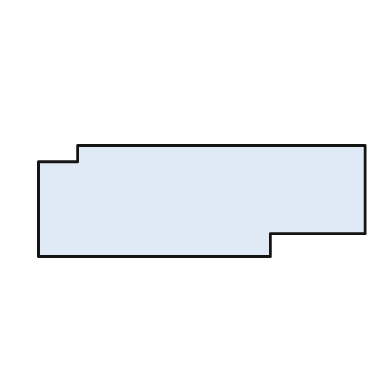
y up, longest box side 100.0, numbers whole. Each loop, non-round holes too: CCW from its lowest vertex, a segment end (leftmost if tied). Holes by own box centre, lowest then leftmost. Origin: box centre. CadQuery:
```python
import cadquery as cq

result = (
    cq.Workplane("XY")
    .moveTo(-50.0, -17.0)
    .lineTo(21.0, -17.0)
    .lineTo(21.0, -10.0)
    .lineTo(50.0, -10.0)
    .lineTo(50.0, 17.0)
    .lineTo(-38.0, 17.0)
    .lineTo(-38.0, 12.0)
    .lineTo(-50.0, 12.0)
    .close()
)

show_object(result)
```